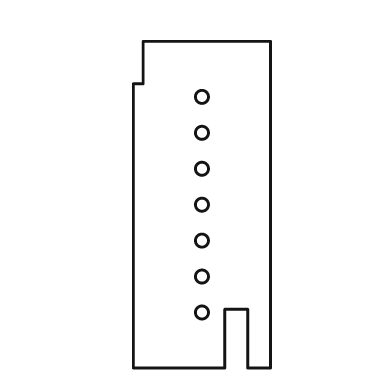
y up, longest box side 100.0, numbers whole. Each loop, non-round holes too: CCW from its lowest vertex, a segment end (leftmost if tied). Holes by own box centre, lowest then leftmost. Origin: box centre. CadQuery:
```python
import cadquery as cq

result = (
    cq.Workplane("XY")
    .moveTo(-21.0, -50.0)
    .lineTo(7.0, -50.0)
    .lineTo(7.0, -32.0)
    .lineTo(14.0, -32.0)
    .lineTo(14.0, -50.0)
    .lineTo(21.0, -50.0)
    .lineTo(21.0, 50.0)
    .lineTo(-18.0, 50.0)
    .lineTo(-18.0, 37.0)
    .lineTo(-21.0, 37.0)
    .close()
    .moveTo(0.0, -33.0)
    .circle(2.0)
    .moveTo(0.0, -22.0)
    .circle(2.0)
    .moveTo(0.0, -11.0)
    .circle(2.0)
    .moveTo(0.0, 0.0)
    .circle(2.0)
    .moveTo(0.0, 11.0)
    .circle(2.0)
    .moveTo(0.0, 22.0)
    .circle(2.0)
    .moveTo(0.0, 33.0)
    .circle(2.0)
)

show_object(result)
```